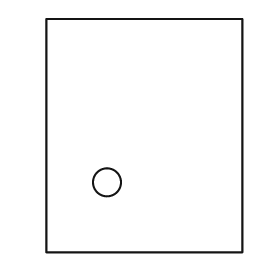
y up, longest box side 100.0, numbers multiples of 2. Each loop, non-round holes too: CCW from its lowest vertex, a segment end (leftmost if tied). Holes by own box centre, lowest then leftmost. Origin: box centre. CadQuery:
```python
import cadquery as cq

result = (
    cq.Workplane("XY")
    .moveTo(-42.0, -50.0)
    .lineTo(42.0, -50.0)
    .lineTo(42.0, 50.0)
    .lineTo(-42.0, 50.0)
    .close()
    .moveTo(-16.0, -20.0)
    .circle(6.0)
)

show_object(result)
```